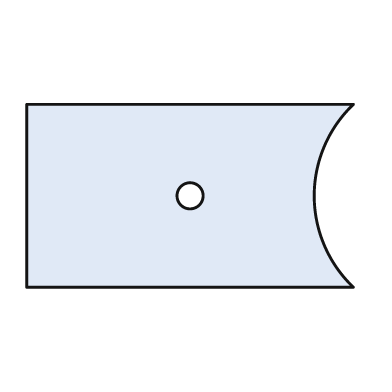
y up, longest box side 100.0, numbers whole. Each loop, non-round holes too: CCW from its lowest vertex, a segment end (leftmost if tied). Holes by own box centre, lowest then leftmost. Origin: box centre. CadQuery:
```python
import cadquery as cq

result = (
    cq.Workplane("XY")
    .moveTo(-50.0, -28.0)
    .lineTo(50.0, -28.0)
    .threePointArc((38.0, 0.0), (50.0, 28.0))
    .lineTo(-50.0, 28.0)
    .close()
    .moveTo(0.0, 0.0)
    .circle(4.0)
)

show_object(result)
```